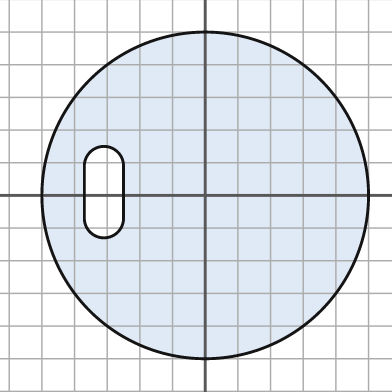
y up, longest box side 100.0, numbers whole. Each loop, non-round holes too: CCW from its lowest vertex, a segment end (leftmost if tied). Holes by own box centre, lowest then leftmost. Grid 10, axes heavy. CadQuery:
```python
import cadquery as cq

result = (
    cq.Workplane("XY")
    .moveTo(0.0, 0.0)
    .circle(50.0)
    .moveTo(-37.0, -7.0)
    .threePointArc((-31.0, -13.0), (-25.0, -7.0))
    .lineTo(-25.0, 9.0)
    .threePointArc((-31.0, 15.0), (-37.0, 9.0))
    .close()
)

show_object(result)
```